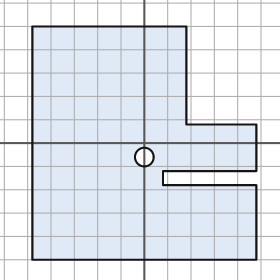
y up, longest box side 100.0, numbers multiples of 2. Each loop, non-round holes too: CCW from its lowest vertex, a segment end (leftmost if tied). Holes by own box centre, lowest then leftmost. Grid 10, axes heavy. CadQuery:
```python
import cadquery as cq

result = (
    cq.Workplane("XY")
    .moveTo(-48.0, -50.0)
    .lineTo(48.0, -50.0)
    .lineTo(48.0, -18.0)
    .lineTo(8.0, -18.0)
    .lineTo(8.0, -12.0)
    .lineTo(48.0, -12.0)
    .lineTo(48.0, 8.0)
    .lineTo(18.0, 8.0)
    .lineTo(18.0, 50.0)
    .lineTo(-48.0, 50.0)
    .close()
    .moveTo(0.0, -6.0)
    .circle(4.0)
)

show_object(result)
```